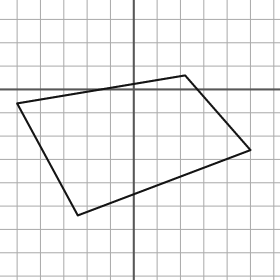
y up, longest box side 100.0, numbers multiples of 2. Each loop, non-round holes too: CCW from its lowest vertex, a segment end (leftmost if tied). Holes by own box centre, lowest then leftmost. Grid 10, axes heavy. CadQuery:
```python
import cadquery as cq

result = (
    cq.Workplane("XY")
    .moveTo(-24.0, -54.0)
    .lineTo(50.0, -26.0)
    .lineTo(22.0, 6.0)
    .lineTo(-50.0, -6.0)
    .close()
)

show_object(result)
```